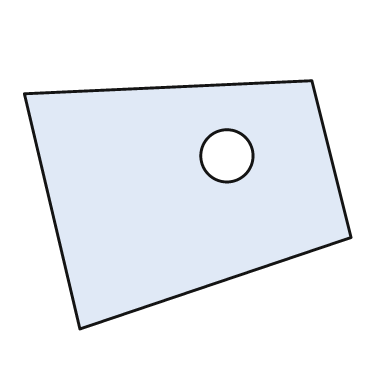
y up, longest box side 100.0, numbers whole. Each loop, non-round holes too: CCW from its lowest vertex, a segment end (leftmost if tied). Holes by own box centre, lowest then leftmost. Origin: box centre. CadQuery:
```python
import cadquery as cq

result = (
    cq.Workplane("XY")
    .moveTo(-33.0, -38.0)
    .lineTo(50.0, -10.0)
    .lineTo(38.0, 38.0)
    .lineTo(-50.0, 34.0)
    .close()
    .moveTo(12.0, 15.0)
    .circle(8.0)
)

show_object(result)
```